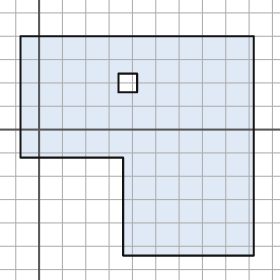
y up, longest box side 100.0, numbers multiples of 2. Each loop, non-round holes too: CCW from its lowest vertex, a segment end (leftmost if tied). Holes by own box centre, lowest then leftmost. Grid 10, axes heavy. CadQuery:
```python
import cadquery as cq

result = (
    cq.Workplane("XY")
    .moveTo(36.0, -54.0)
    .lineTo(92.0, -54.0)
    .lineTo(92.0, 40.0)
    .lineTo(-8.0, 40.0)
    .lineTo(-8.0, -12.0)
    .lineTo(36.0, -12.0)
    .close()
    .moveTo(34.0, 16.0)
    .lineTo(42.0, 16.0)
    .lineTo(42.0, 24.0)
    .lineTo(34.0, 24.0)
    .close()
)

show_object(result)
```